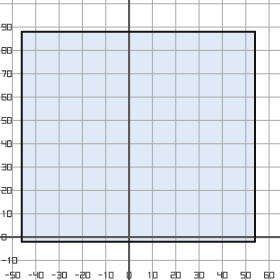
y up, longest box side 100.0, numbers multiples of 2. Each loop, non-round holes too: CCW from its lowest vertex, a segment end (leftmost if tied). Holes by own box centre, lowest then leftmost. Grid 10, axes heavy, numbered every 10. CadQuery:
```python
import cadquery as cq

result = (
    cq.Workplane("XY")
    .moveTo(-46.0, -2.0)
    .lineTo(54.0, -2.0)
    .lineTo(54.0, 88.0)
    .lineTo(-46.0, 88.0)
    .close()
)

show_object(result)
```